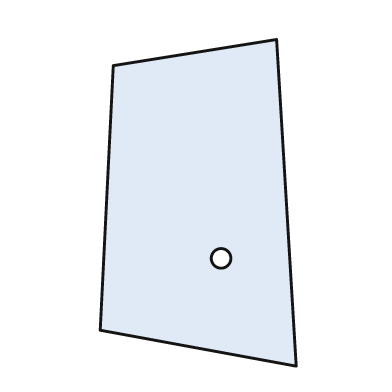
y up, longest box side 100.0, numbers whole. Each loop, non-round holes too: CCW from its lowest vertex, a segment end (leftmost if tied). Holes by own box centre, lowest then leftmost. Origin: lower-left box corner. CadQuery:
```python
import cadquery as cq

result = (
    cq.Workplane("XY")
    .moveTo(60.0, 0.0)
    .lineTo(54.0, 100.0)
    .lineTo(4.0, 92.0)
    .lineTo(0.0, 11.0)
    .close()
    .moveTo(37.0, 33.0)
    .circle(3.0)
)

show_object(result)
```